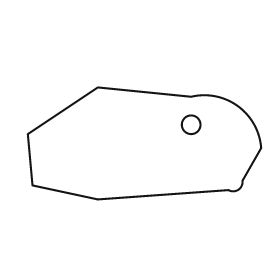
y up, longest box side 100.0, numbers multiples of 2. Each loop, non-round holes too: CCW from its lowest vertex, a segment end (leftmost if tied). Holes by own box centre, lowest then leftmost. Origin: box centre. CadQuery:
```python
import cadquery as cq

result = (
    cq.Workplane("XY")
    .moveTo(-20.0, -24.0)
    .lineTo(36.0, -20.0)
    .threePointArc((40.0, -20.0), (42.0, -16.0))
    .lineTo(50.0, -2.0)
    .threePointArc((40.0, 16.0), (20.0, 20.0))
    .lineTo(-20.0, 24.0)
    .lineTo(-50.0, 4.0)
    .lineTo(-48.0, -18.0)
    .close()
    .moveTo(20.0, 8.0)
    .circle(4.0)
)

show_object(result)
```